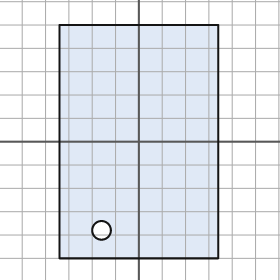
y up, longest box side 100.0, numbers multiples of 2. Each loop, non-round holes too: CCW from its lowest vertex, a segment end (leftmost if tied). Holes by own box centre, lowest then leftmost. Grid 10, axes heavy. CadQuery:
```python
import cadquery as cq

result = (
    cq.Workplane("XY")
    .moveTo(-34.0, -50.0)
    .lineTo(34.0, -50.0)
    .lineTo(34.0, 50.0)
    .lineTo(-34.0, 50.0)
    .close()
    .moveTo(-16.0, -38.0)
    .circle(4.0)
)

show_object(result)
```